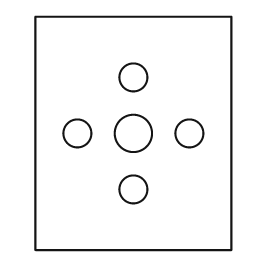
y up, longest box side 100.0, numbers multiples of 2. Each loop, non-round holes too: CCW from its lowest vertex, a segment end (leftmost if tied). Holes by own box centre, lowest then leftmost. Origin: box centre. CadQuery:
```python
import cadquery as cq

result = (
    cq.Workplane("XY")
    .moveTo(-42.0, -50.0)
    .lineTo(42.0, -50.0)
    .lineTo(42.0, 50.0)
    .lineTo(-42.0, 50.0)
    .close()
    .moveTo(0.0, -24.0)
    .circle(6.0)
    .moveTo(-24.0, 0.0)
    .circle(6.0)
    .moveTo(0.0, 0.0)
    .circle(8.0)
    .moveTo(24.0, 0.0)
    .circle(6.0)
    .moveTo(0.0, 24.0)
    .circle(6.0)
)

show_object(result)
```